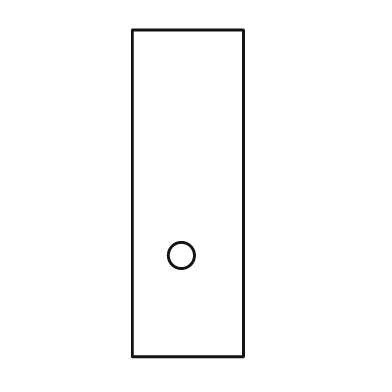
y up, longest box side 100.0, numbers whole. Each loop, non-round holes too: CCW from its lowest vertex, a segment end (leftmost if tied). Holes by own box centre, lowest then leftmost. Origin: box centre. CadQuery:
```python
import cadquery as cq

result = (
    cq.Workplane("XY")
    .moveTo(-17.0, -50.0)
    .lineTo(17.0, -50.0)
    .lineTo(17.0, 50.0)
    .lineTo(-17.0, 50.0)
    .close()
    .moveTo(-2.0, -19.0)
    .circle(4.0)
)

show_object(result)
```